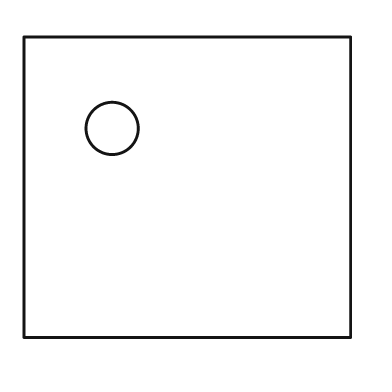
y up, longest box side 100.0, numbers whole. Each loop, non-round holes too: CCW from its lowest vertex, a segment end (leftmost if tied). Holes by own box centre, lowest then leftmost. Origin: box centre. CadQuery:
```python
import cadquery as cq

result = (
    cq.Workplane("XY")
    .moveTo(-50.0, -46.0)
    .lineTo(50.0, -46.0)
    .lineTo(50.0, 46.0)
    .lineTo(-50.0, 46.0)
    .close()
    .moveTo(-23.0, 18.0)
    .circle(8.0)
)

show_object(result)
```